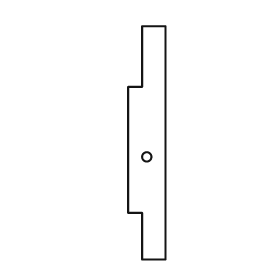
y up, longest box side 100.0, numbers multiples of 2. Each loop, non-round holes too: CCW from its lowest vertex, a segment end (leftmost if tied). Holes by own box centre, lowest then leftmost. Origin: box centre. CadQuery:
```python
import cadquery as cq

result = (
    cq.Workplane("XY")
    .moveTo(-2.0, -50.0)
    .lineTo(8.0, -50.0)
    .lineTo(8.0, 50.0)
    .lineTo(-2.0, 50.0)
    .lineTo(-2.0, 24.0)
    .lineTo(-8.0, 24.0)
    .lineTo(-8.0, -30.0)
    .lineTo(-2.0, -30.0)
    .close()
    .moveTo(0.0, -6.0)
    .circle(2.0)
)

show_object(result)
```